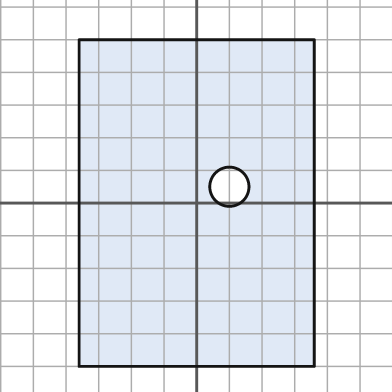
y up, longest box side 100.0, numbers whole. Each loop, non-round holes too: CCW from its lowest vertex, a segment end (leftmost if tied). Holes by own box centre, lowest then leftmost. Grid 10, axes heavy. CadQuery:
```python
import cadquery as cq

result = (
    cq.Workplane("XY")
    .moveTo(-36.0, -50.0)
    .lineTo(36.0, -50.0)
    .lineTo(36.0, 50.0)
    .lineTo(-36.0, 50.0)
    .close()
    .moveTo(10.0, 5.0)
    .circle(6.0)
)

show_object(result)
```